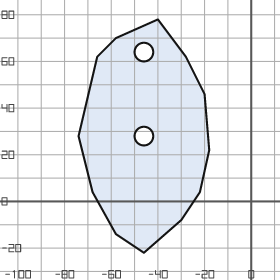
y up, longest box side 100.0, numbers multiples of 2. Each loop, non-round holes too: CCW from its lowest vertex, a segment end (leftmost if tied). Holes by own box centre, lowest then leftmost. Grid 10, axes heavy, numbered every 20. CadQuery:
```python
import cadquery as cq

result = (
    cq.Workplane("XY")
    .moveTo(-46.0, -22.0)
    .lineTo(-30.0, -8.0)
    .lineTo(-22.0, 4.0)
    .lineTo(-18.0, 22.0)
    .lineTo(-20.0, 46.0)
    .lineTo(-28.0, 62.0)
    .lineTo(-40.0, 78.0)
    .lineTo(-58.0, 70.0)
    .lineTo(-66.0, 62.0)
    .lineTo(-74.0, 28.0)
    .lineTo(-68.0, 4.0)
    .lineTo(-58.0, -14.0)
    .close()
    .moveTo(-46.0, 28.0)
    .circle(4.0)
    .moveTo(-46.0, 64.0)
    .circle(4.0)
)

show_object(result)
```